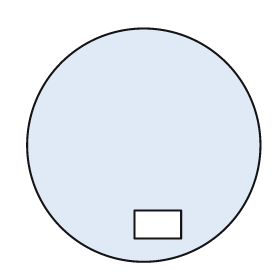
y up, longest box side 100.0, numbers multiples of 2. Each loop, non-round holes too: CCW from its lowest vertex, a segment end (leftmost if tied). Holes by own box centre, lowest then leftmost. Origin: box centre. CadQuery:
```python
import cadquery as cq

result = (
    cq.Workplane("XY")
    .moveTo(0.0, 0.0)
    .circle(50.0)
    .moveTo(-4.0, -40.0)
    .lineTo(16.0, -40.0)
    .lineTo(16.0, -28.0)
    .lineTo(-4.0, -28.0)
    .close()
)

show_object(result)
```